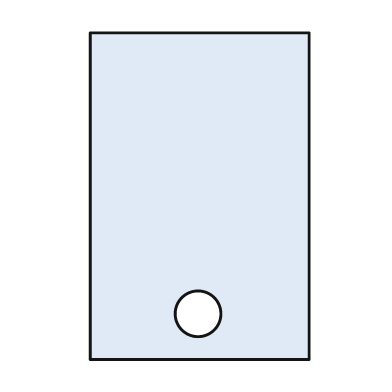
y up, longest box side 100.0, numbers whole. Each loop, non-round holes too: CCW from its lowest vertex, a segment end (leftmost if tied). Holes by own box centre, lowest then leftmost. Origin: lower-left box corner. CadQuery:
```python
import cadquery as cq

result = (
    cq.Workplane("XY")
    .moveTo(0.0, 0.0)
    .lineTo(67.0, 0.0)
    .lineTo(67.0, 100.0)
    .lineTo(0.0, 100.0)
    .close()
    .moveTo(33.0, 14.0)
    .circle(7.0)
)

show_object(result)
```